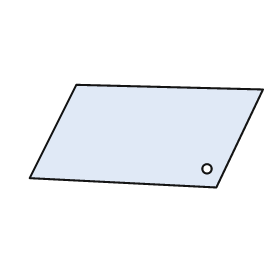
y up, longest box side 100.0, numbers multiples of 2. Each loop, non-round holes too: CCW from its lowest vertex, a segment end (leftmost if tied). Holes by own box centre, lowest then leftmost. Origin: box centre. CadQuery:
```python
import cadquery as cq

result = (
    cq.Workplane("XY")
    .moveTo(30.0, -22.0)
    .lineTo(50.0, 20.0)
    .lineTo(-30.0, 22.0)
    .lineTo(-50.0, -18.0)
    .close()
    .moveTo(26.0, -14.0)
    .circle(2.0)
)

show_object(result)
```